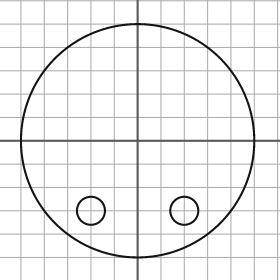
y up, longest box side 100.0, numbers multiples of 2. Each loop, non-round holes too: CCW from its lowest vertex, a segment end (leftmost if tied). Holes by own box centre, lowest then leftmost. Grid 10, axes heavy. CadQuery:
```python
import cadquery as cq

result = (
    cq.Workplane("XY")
    .moveTo(0.0, 0.0)
    .circle(50.0)
    .moveTo(-20.0, -30.0)
    .circle(6.0)
    .moveTo(20.0, -30.0)
    .circle(6.0)
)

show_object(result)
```